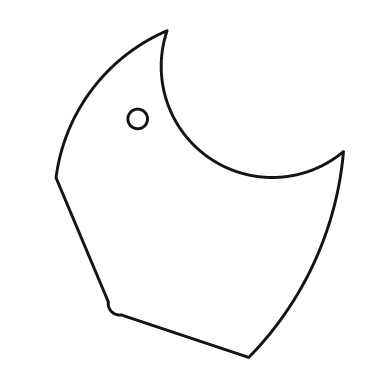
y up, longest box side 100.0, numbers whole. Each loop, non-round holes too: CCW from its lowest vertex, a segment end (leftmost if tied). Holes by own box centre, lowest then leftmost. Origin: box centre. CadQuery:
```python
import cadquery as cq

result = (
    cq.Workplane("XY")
    .moveTo(15.0, -50.0)
    .threePointArc((35.0, -21.0), (44.0, 13.0))
    .threePointArc((3.0, 11.0), (-10.0, 50.0))
    .threePointArc((-33.0, 32.0), (-44.0, 5.0))
    .lineTo(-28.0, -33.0)
    .threePointArc((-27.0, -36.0), (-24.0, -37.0))
    .close()
    .moveTo(-19.0, 23.0)
    .circle(3.0)
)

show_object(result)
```